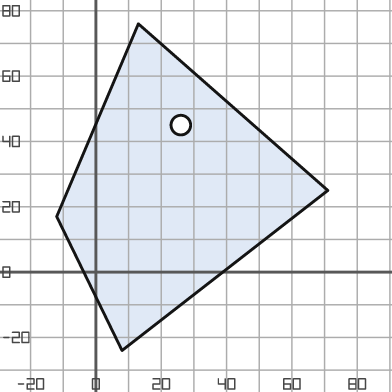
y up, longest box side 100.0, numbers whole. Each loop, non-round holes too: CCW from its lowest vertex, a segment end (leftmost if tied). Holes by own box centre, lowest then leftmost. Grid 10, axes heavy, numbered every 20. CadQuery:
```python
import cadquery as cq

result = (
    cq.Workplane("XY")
    .moveTo(8.0, -24.0)
    .lineTo(71.0, 25.0)
    .lineTo(13.0, 76.0)
    .lineTo(-12.0, 17.0)
    .close()
    .moveTo(26.0, 45.0)
    .circle(3.0)
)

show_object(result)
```